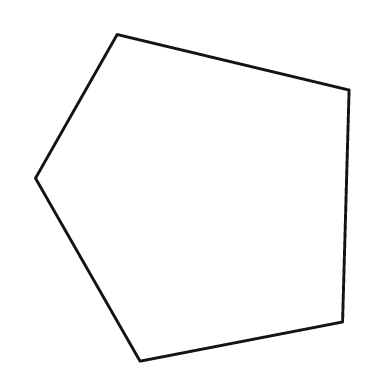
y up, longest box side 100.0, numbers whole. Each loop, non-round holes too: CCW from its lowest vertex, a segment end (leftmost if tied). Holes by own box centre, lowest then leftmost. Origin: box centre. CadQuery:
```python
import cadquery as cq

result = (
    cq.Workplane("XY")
    .moveTo(-16.0, -50.0)
    .lineTo(46.0, -38.0)
    .lineTo(48.0, 33.0)
    .lineTo(-23.0, 50.0)
    .lineTo(-48.0, 6.0)
    .close()
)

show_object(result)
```